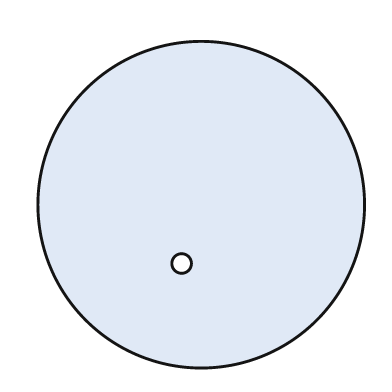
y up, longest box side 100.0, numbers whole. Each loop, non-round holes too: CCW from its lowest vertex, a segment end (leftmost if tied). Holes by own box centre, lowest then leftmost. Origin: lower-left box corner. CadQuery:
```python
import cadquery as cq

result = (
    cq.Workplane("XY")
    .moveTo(50.0, 50.0)
    .circle(50.0)
    .moveTo(44.0, 32.0)
    .circle(3.0)
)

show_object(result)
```